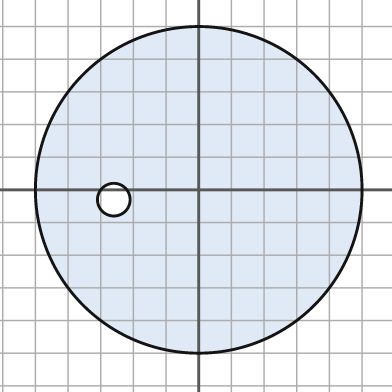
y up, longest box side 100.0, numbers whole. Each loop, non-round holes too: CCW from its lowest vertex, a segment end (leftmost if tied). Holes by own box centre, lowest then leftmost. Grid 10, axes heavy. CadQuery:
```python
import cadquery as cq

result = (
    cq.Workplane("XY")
    .moveTo(0.0, 0.0)
    .circle(50.0)
    .moveTo(-26.0, -3.0)
    .circle(5.0)
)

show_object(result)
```